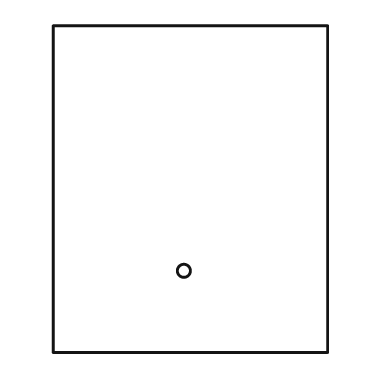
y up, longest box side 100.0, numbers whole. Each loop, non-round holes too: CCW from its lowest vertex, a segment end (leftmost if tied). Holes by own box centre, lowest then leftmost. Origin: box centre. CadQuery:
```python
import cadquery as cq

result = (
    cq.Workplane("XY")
    .moveTo(-42.0, -50.0)
    .lineTo(42.0, -50.0)
    .lineTo(42.0, 50.0)
    .lineTo(-42.0, 50.0)
    .close()
    .moveTo(-2.0, -25.0)
    .circle(2.0)
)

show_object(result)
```